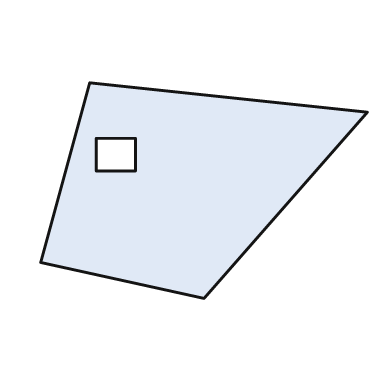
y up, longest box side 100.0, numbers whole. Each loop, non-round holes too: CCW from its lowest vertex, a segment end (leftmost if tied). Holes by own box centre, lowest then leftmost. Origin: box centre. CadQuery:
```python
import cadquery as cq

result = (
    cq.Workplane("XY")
    .moveTo(0.0, -33.0)
    .lineTo(50.0, 24.0)
    .lineTo(-35.0, 33.0)
    .lineTo(-50.0, -22.0)
    .close()
    .moveTo(-33.0, 6.0)
    .lineTo(-21.0, 6.0)
    .lineTo(-21.0, 16.0)
    .lineTo(-33.0, 16.0)
    .close()
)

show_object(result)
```